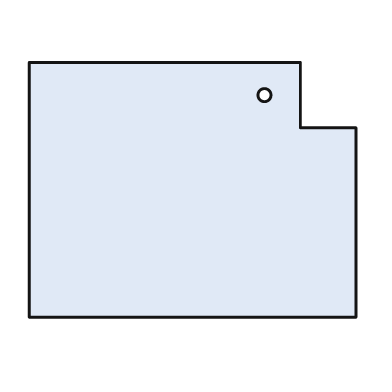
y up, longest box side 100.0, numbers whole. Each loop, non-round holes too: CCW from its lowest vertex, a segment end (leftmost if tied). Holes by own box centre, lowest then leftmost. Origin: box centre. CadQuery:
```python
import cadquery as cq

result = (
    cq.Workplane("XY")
    .moveTo(-50.0, -39.0)
    .lineTo(50.0, -39.0)
    .lineTo(50.0, 19.0)
    .lineTo(33.0, 19.0)
    .lineTo(33.0, 39.0)
    .lineTo(-50.0, 39.0)
    .close()
    .moveTo(22.0, 29.0)
    .circle(2.0)
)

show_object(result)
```